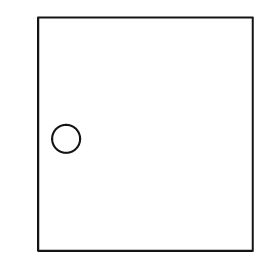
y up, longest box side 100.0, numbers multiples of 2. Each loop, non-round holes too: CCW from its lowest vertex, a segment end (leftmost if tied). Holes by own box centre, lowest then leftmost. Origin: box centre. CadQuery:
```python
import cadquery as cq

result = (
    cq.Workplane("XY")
    .moveTo(-46.0, -50.0)
    .lineTo(46.0, -50.0)
    .lineTo(46.0, 50.0)
    .lineTo(-46.0, 50.0)
    .close()
    .moveTo(-34.0, -2.0)
    .circle(6.0)
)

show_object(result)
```